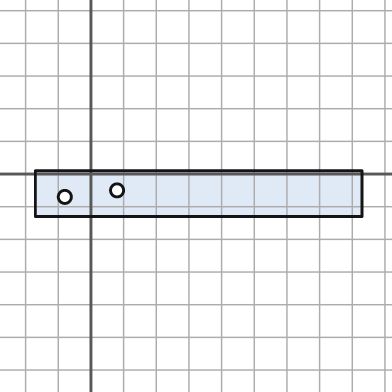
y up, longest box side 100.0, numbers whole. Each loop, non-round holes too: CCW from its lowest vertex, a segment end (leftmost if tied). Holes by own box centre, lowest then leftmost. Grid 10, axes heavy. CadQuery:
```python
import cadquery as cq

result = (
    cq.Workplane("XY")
    .moveTo(-17.0, -13.0)
    .lineTo(83.0, -13.0)
    .lineTo(83.0, 1.0)
    .lineTo(-17.0, 1.0)
    .close()
    .moveTo(-8.0, -7.0)
    .circle(2.0)
    .moveTo(8.0, -5.0)
    .circle(2.0)
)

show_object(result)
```